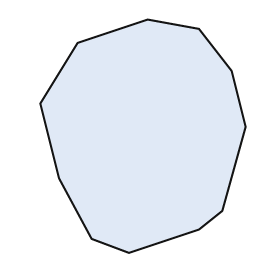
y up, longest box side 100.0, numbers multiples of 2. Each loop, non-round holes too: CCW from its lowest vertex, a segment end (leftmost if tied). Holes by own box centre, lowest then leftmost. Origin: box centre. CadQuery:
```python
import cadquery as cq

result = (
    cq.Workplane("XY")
    .moveTo(-6.0, -50.0)
    .lineTo(24.0, -40.0)
    .lineTo(34.0, -32.0)
    .lineTo(44.0, 4.0)
    .lineTo(38.0, 28.0)
    .lineTo(24.0, 46.0)
    .lineTo(2.0, 50.0)
    .lineTo(-28.0, 40.0)
    .lineTo(-44.0, 14.0)
    .lineTo(-36.0, -18.0)
    .lineTo(-22.0, -44.0)
    .close()
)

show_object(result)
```